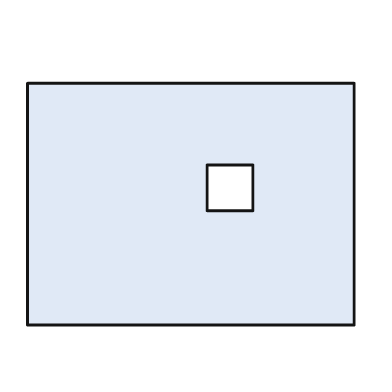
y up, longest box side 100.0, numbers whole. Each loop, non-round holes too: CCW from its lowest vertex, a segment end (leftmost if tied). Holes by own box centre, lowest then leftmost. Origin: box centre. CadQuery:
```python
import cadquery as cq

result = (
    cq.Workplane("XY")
    .moveTo(-50.0, -37.0)
    .lineTo(50.0, -37.0)
    .lineTo(50.0, 37.0)
    .lineTo(-50.0, 37.0)
    .close()
    .moveTo(5.0, -2.0)
    .lineTo(19.0, -2.0)
    .lineTo(19.0, 12.0)
    .lineTo(5.0, 12.0)
    .close()
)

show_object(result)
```